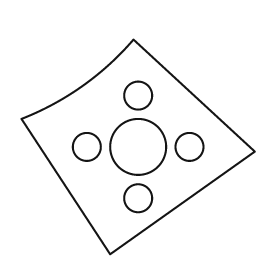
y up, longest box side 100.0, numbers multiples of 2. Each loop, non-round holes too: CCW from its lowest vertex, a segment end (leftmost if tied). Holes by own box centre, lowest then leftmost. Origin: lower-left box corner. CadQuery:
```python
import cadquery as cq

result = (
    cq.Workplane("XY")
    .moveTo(38.0, 0.0)
    .lineTo(100.0, 44.0)
    .lineTo(48.0, 92.0)
    .threePointArc((26.0, 72.0), (0.0, 58.0))
    .close()
    .moveTo(50.0, 24.0)
    .circle(6.0)
    .moveTo(28.0, 46.0)
    .circle(6.0)
    .moveTo(50.0, 46.0)
    .circle(12.0)
    .moveTo(72.0, 46.0)
    .circle(6.0)
    .moveTo(50.0, 68.0)
    .circle(6.0)
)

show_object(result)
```